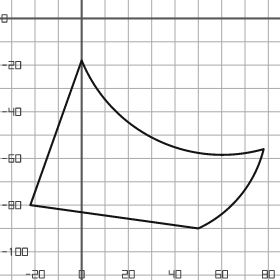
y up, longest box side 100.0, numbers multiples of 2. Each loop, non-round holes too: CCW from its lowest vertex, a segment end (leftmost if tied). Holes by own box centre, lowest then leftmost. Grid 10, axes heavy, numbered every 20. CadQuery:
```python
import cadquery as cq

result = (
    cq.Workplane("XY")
    .moveTo(50.0, -90.0)
    .threePointArc((68.0, -76.0), (78.0, -56.0))
    .threePointArc((32.0, -52.0), (0.0, -18.0))
    .lineTo(-22.0, -80.0)
    .close()
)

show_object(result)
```